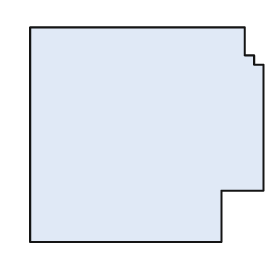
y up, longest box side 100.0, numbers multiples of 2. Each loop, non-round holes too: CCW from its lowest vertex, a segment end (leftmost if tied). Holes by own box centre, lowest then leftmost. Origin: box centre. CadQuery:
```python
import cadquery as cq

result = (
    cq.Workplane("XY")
    .moveTo(-50.0, -46.0)
    .lineTo(32.0, -46.0)
    .lineTo(32.0, -24.0)
    .lineTo(50.0, -24.0)
    .lineTo(50.0, 30.0)
    .lineTo(46.0, 30.0)
    .lineTo(46.0, 34.0)
    .lineTo(42.0, 34.0)
    .lineTo(42.0, 46.0)
    .lineTo(-50.0, 46.0)
    .close()
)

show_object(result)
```